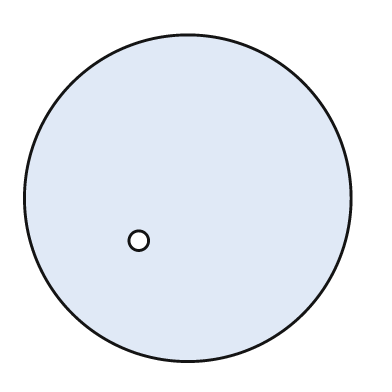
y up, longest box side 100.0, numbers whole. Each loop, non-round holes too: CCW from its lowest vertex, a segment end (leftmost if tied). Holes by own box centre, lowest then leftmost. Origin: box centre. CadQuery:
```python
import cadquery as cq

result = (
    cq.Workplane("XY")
    .moveTo(0.0, 0.0)
    .circle(50.0)
    .moveTo(-15.0, -13.0)
    .circle(3.0)
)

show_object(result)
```